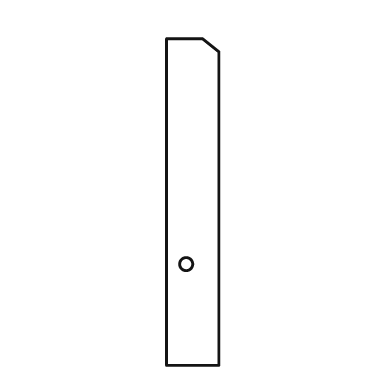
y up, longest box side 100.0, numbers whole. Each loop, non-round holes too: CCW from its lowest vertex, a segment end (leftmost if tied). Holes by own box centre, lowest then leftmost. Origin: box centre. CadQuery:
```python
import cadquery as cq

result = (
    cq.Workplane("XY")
    .moveTo(-8.0, -50.0)
    .lineTo(8.0, -50.0)
    .lineTo(8.0, 46.0)
    .lineTo(3.0, 50.0)
    .lineTo(-8.0, 50.0)
    .close()
    .moveTo(-2.0, -19.0)
    .circle(2.0)
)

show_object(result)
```